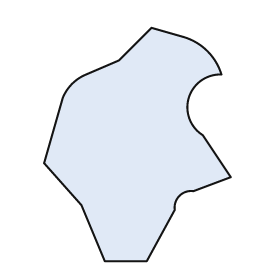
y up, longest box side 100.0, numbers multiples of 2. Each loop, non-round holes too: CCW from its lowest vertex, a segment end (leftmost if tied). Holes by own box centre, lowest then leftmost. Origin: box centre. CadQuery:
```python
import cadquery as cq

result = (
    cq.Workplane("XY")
    .moveTo(-14.0, -50.0)
    .lineTo(4.0, -50.0)
    .lineTo(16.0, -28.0)
    .threePointArc((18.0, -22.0), (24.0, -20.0))
    .lineTo(40.0, -14.0)
    .lineTo(28.0, 4.0)
    .threePointArc((22.0, 20.0), (36.0, 30.0))
    .threePointArc((30.0, 40.0), (20.0, 46.0))
    .lineTo(6.0, 50.0)
    .lineTo(-8.0, 36.0)
    .lineTo(-22.0, 30.0)
    .threePointArc((-28.0, 26.0), (-32.0, 20.0))
    .lineTo(-40.0, -8.0)
    .lineTo(-24.0, -26.0)
    .close()
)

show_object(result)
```